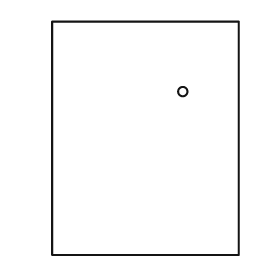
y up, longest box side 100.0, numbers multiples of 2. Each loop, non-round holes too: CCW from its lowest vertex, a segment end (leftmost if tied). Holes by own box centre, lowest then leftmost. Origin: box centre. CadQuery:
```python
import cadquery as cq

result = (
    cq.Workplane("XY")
    .moveTo(-40.0, -50.0)
    .lineTo(40.0, -50.0)
    .lineTo(40.0, 50.0)
    .lineTo(-40.0, 50.0)
    .close()
    .moveTo(16.0, 20.0)
    .circle(2.0)
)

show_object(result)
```